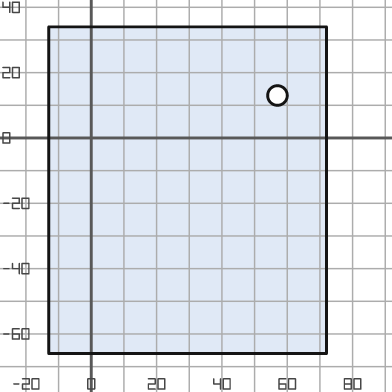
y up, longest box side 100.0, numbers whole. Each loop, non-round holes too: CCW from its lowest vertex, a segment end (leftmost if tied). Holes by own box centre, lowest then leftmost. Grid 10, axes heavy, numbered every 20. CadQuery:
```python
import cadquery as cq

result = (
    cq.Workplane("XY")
    .moveTo(-13.0, -66.0)
    .lineTo(72.0, -66.0)
    .lineTo(72.0, 34.0)
    .lineTo(-13.0, 34.0)
    .close()
    .moveTo(57.0, 13.0)
    .circle(3.0)
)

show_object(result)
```